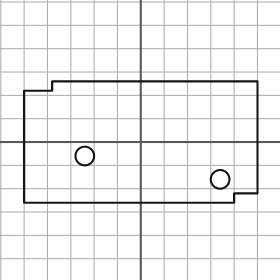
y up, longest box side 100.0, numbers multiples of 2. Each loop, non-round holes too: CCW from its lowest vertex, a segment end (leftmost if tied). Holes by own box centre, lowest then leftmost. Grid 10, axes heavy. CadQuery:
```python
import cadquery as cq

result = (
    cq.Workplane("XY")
    .moveTo(-50.0, -26.0)
    .lineTo(40.0, -26.0)
    .lineTo(40.0, -22.0)
    .lineTo(50.0, -22.0)
    .lineTo(50.0, 26.0)
    .lineTo(-38.0, 26.0)
    .lineTo(-38.0, 22.0)
    .lineTo(-50.0, 22.0)
    .close()
    .moveTo(34.0, -16.0)
    .circle(4.0)
    .moveTo(-24.0, -6.0)
    .circle(4.0)
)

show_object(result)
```